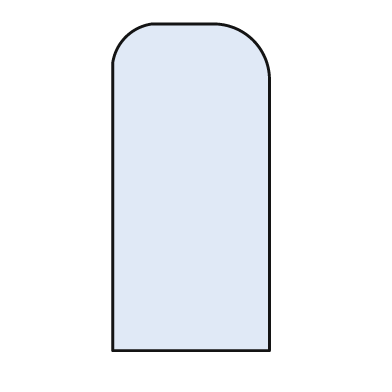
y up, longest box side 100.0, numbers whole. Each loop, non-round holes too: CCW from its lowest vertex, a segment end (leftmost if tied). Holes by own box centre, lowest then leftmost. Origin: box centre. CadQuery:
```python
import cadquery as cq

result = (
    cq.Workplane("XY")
    .moveTo(-24.0, -50.0)
    .lineTo(24.0, -50.0)
    .lineTo(24.0, 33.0)
    .threePointArc((19.0, 45.0), (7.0, 50.0))
    .lineTo(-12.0, 50.0)
    .threePointArc((-20.0, 46.0), (-24.0, 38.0))
    .close()
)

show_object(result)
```